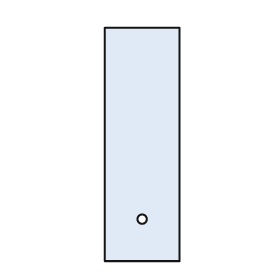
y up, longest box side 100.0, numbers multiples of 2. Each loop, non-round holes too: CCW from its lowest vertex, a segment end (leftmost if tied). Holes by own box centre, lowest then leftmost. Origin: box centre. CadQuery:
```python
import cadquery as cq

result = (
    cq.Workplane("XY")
    .moveTo(-16.0, -50.0)
    .lineTo(16.0, -50.0)
    .lineTo(16.0, 50.0)
    .lineTo(-16.0, 50.0)
    .close()
    .moveTo(0.0, -32.0)
    .circle(2.0)
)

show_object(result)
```